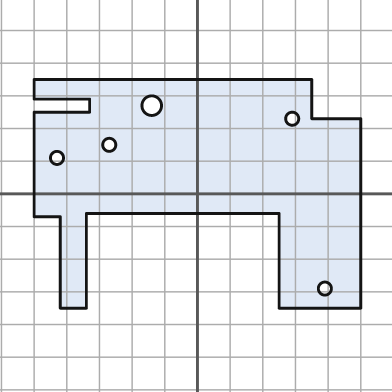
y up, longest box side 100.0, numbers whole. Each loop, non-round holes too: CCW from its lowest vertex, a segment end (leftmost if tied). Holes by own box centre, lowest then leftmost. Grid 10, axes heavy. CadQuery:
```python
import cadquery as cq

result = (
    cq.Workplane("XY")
    .moveTo(-42.0, -35.0)
    .lineTo(-34.0, -35.0)
    .lineTo(-34.0, -6.0)
    .lineTo(25.0, -6.0)
    .lineTo(25.0, -35.0)
    .lineTo(50.0, -35.0)
    .lineTo(50.0, 23.0)
    .lineTo(35.0, 23.0)
    .lineTo(35.0, 35.0)
    .lineTo(-50.0, 35.0)
    .lineTo(-50.0, 29.0)
    .lineTo(-33.0, 29.0)
    .lineTo(-33.0, 25.0)
    .lineTo(-50.0, 25.0)
    .lineTo(-50.0, -7.0)
    .lineTo(-42.0, -7.0)
    .close()
    .moveTo(39.0, -29.0)
    .circle(2.0)
    .moveTo(-43.0, 11.0)
    .circle(2.0)
    .moveTo(-27.0, 15.0)
    .circle(2.0)
    .moveTo(29.0, 23.0)
    .circle(2.0)
    .moveTo(-14.0, 27.0)
    .circle(3.0)
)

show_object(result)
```